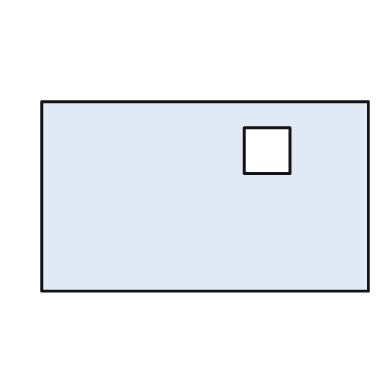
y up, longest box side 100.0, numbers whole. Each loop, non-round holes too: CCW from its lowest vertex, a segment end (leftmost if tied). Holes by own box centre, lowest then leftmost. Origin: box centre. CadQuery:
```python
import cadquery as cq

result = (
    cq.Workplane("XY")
    .moveTo(-50.0, -29.0)
    .lineTo(50.0, -29.0)
    .lineTo(50.0, 29.0)
    .lineTo(-50.0, 29.0)
    .close()
    .moveTo(12.0, 7.0)
    .lineTo(26.0, 7.0)
    .lineTo(26.0, 21.0)
    .lineTo(12.0, 21.0)
    .close()
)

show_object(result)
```